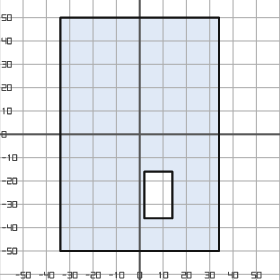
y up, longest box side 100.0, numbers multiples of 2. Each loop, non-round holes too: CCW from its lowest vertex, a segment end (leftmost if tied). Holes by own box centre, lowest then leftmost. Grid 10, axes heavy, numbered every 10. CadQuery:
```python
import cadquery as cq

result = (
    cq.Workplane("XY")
    .moveTo(-34.0, -50.0)
    .lineTo(34.0, -50.0)
    .lineTo(34.0, 50.0)
    .lineTo(-34.0, 50.0)
    .close()
    .moveTo(2.0, -36.0)
    .lineTo(14.0, -36.0)
    .lineTo(14.0, -16.0)
    .lineTo(2.0, -16.0)
    .close()
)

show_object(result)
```